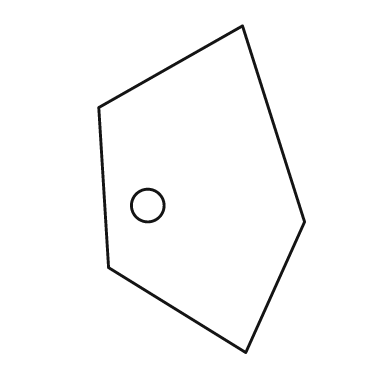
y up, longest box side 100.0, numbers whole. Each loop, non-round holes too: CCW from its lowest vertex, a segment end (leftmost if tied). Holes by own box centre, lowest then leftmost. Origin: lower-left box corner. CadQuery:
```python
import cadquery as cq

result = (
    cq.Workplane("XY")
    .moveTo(45.0, 0.0)
    .lineTo(63.0, 40.0)
    .lineTo(44.0, 100.0)
    .lineTo(0.0, 75.0)
    .lineTo(3.0, 26.0)
    .close()
    .moveTo(15.0, 45.0)
    .circle(5.0)
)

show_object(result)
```